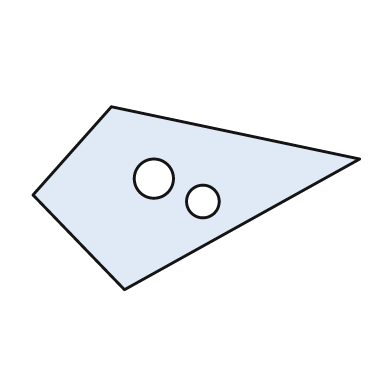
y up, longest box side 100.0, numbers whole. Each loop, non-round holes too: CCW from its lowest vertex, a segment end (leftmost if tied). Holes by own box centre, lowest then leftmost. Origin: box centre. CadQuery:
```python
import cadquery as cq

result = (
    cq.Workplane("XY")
    .moveTo(-22.0, -28.0)
    .lineTo(50.0, 12.0)
    .lineTo(-26.0, 28.0)
    .lineTo(-50.0, 1.0)
    .close()
    .moveTo(2.0, -1.0)
    .circle(5.0)
    .moveTo(-13.0, 6.0)
    .circle(6.0)
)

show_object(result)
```